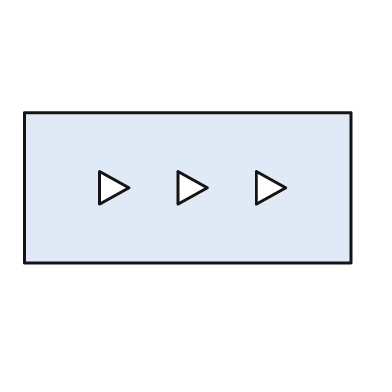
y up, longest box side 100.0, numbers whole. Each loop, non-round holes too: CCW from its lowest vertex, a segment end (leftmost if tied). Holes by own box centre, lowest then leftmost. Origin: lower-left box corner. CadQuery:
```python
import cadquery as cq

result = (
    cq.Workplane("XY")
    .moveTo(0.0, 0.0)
    .lineTo(100.0, 0.0)
    .lineTo(100.0, 46.0)
    .lineTo(0.0, 46.0)
    .close()
    .moveTo(23.0, 18.0)
    .lineTo(32.0, 23.0)
    .lineTo(23.0, 28.0)
    .close()
    .moveTo(47.0, 18.0)
    .lineTo(56.0, 23.0)
    .lineTo(47.0, 28.0)
    .close()
    .moveTo(71.0, 18.0)
    .lineTo(80.0, 23.0)
    .lineTo(71.0, 28.0)
    .close()
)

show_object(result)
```